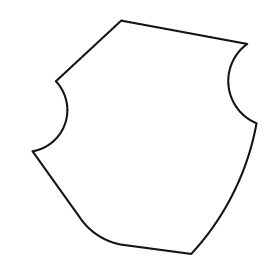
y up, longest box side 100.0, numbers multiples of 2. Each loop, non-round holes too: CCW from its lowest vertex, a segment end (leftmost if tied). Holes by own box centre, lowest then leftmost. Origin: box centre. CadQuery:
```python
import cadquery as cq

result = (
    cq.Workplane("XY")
    .moveTo(20.0, -50.0)
    .threePointArc((38.0, -24.0), (48.0, 6.0))
    .threePointArc((36.0, 22.0), (44.0, 40.0))
    .lineTo(-10.0, 50.0)
    .lineTo(-38.0, 24.0)
    .threePointArc((-34.0, 6.0), (-48.0, -6.0))
    .lineTo(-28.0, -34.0)
    .threePointArc((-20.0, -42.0), (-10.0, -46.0))
    .close()
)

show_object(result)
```